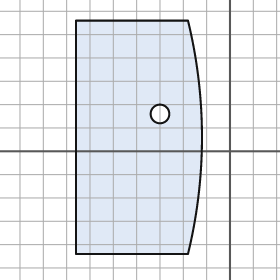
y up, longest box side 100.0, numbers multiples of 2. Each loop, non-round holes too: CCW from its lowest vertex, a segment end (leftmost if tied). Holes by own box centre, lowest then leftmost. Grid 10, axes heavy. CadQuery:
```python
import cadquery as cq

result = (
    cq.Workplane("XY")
    .moveTo(-66.0, -44.0)
    .lineTo(-18.0, -44.0)
    .threePointArc((-12.0, 6.0), (-18.0, 56.0))
    .lineTo(-66.0, 56.0)
    .close()
    .moveTo(-30.0, 16.0)
    .circle(4.0)
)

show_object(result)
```